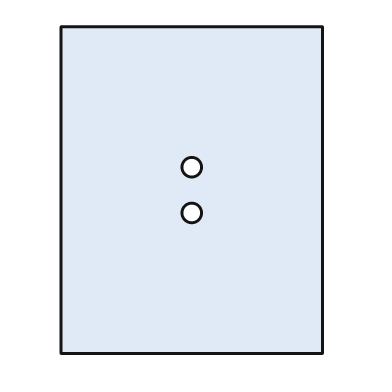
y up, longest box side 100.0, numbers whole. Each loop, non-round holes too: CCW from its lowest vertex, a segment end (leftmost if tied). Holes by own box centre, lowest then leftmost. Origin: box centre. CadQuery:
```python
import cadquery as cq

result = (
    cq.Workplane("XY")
    .moveTo(-40.0, -50.0)
    .lineTo(40.0, -50.0)
    .lineTo(40.0, 50.0)
    .lineTo(-40.0, 50.0)
    .close()
    .moveTo(0.0, -7.0)
    .circle(3.0)
    .moveTo(0.0, 7.0)
    .circle(3.0)
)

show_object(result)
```